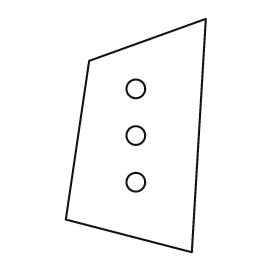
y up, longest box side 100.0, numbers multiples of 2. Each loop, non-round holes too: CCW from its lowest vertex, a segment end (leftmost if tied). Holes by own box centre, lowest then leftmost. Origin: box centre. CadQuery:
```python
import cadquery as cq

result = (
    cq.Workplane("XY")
    .moveTo(24.0, -50.0)
    .lineTo(30.0, 50.0)
    .lineTo(-20.0, 32.0)
    .lineTo(-30.0, -36.0)
    .close()
    .moveTo(0.0, -20.0)
    .circle(4.0)
    .moveTo(0.0, 0.0)
    .circle(4.0)
    .moveTo(0.0, 20.0)
    .circle(4.0)
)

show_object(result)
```